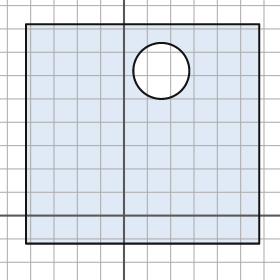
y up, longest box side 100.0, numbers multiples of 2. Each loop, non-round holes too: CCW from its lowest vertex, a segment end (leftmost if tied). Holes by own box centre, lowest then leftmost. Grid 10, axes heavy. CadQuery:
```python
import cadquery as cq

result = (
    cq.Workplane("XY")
    .moveTo(-42.0, -12.0)
    .lineTo(58.0, -12.0)
    .lineTo(58.0, 82.0)
    .lineTo(-42.0, 82.0)
    .close()
    .moveTo(16.0, 62.0)
    .circle(12.0)
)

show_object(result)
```